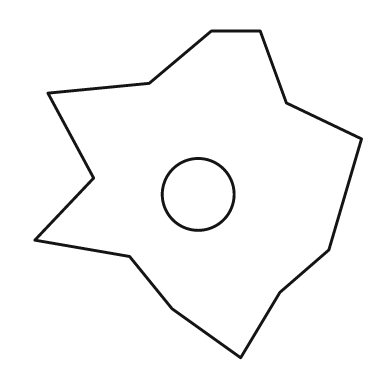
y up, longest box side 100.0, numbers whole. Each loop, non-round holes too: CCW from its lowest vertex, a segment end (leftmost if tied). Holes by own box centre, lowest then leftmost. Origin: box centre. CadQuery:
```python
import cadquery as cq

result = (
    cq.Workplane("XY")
    .moveTo(13.0, -50.0)
    .lineTo(25.0, -30.0)
    .lineTo(40.0, -17.0)
    .lineTo(50.0, 17.0)
    .lineTo(27.0, 28.0)
    .lineTo(19.0, 50.0)
    .lineTo(4.0, 50.0)
    .lineTo(-15.0, 34.0)
    .lineTo(-46.0, 31.0)
    .lineTo(-32.0, 5.0)
    .lineTo(-50.0, -14.0)
    .lineTo(-21.0, -19.0)
    .lineTo(-8.0, -35.0)
    .close()
    .moveTo(0.0, 0.0)
    .circle(11.0)
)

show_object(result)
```